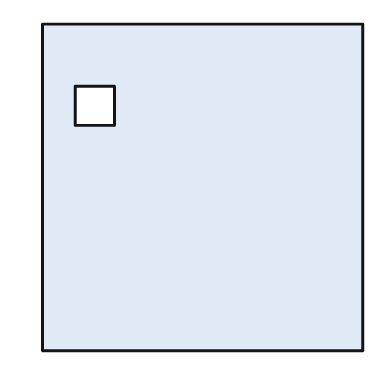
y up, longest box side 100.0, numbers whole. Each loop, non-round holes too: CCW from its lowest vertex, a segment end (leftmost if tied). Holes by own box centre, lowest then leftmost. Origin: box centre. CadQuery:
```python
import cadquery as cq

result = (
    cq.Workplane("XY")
    .moveTo(-49.0, -50.0)
    .lineTo(49.0, -50.0)
    .lineTo(49.0, 50.0)
    .lineTo(-49.0, 50.0)
    .close()
    .moveTo(-39.0, 19.0)
    .lineTo(-27.0, 19.0)
    .lineTo(-27.0, 31.0)
    .lineTo(-39.0, 31.0)
    .close()
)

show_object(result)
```